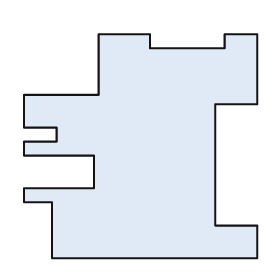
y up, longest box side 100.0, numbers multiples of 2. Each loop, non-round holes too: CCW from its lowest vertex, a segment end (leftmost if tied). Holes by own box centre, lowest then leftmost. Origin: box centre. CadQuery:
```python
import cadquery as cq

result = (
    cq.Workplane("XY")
    .moveTo(-38.0, -48.0)
    .lineTo(50.0, -48.0)
    .lineTo(50.0, -34.0)
    .lineTo(32.0, -34.0)
    .lineTo(32.0, 18.0)
    .lineTo(50.0, 18.0)
    .lineTo(50.0, 48.0)
    .lineTo(36.0, 48.0)
    .lineTo(36.0, 42.0)
    .lineTo(4.0, 42.0)
    .lineTo(4.0, 48.0)
    .lineTo(-18.0, 48.0)
    .lineTo(-18.0, 22.0)
    .lineTo(-50.0, 22.0)
    .lineTo(-50.0, 8.0)
    .lineTo(-36.0, 8.0)
    .lineTo(-36.0, 2.0)
    .lineTo(-50.0, 2.0)
    .lineTo(-50.0, -4.0)
    .lineTo(-20.0, -4.0)
    .lineTo(-20.0, -18.0)
    .lineTo(-50.0, -18.0)
    .lineTo(-50.0, -24.0)
    .lineTo(-38.0, -24.0)
    .close()
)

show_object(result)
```